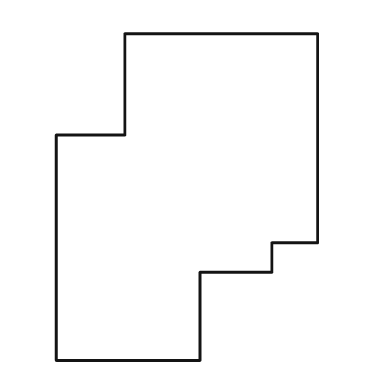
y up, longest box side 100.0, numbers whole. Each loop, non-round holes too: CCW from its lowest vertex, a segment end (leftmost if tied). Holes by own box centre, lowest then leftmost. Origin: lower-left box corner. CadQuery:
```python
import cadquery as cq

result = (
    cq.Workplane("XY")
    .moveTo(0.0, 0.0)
    .lineTo(44.0, 0.0)
    .lineTo(44.0, 27.0)
    .lineTo(66.0, 27.0)
    .lineTo(66.0, 36.0)
    .lineTo(80.0, 36.0)
    .lineTo(80.0, 100.0)
    .lineTo(21.0, 100.0)
    .lineTo(21.0, 69.0)
    .lineTo(0.0, 69.0)
    .close()
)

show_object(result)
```